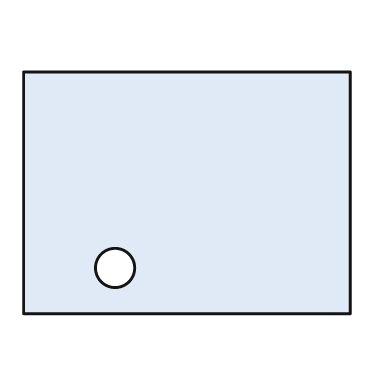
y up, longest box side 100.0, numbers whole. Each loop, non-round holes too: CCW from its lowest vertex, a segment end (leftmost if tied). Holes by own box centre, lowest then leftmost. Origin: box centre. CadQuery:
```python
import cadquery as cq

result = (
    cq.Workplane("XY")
    .moveTo(-50.0, -37.0)
    .lineTo(50.0, -37.0)
    .lineTo(50.0, 37.0)
    .lineTo(-50.0, 37.0)
    .close()
    .moveTo(-22.0, -23.0)
    .circle(6.0)
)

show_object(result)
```